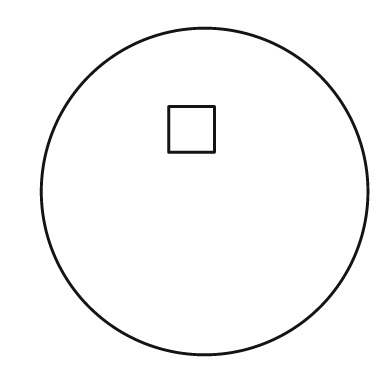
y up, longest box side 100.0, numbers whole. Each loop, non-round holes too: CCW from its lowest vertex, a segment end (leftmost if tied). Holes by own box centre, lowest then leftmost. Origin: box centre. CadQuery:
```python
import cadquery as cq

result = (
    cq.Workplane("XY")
    .moveTo(0.0, 0.0)
    .circle(50.0)
    .moveTo(-11.0, 12.0)
    .lineTo(3.0, 12.0)
    .lineTo(3.0, 26.0)
    .lineTo(-11.0, 26.0)
    .close()
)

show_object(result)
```